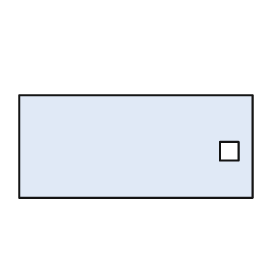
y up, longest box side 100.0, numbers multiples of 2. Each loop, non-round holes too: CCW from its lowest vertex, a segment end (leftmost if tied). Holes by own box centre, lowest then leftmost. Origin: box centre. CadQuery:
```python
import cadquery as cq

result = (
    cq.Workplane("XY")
    .moveTo(-50.0, -22.0)
    .lineTo(50.0, -22.0)
    .lineTo(50.0, 22.0)
    .lineTo(-50.0, 22.0)
    .close()
    .moveTo(36.0, -6.0)
    .lineTo(44.0, -6.0)
    .lineTo(44.0, 2.0)
    .lineTo(36.0, 2.0)
    .close()
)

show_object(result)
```